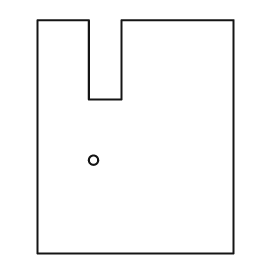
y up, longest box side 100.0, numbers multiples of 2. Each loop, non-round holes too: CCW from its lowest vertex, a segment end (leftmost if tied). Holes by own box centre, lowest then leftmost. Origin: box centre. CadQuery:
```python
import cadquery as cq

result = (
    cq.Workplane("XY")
    .moveTo(-42.0, -50.0)
    .lineTo(42.0, -50.0)
    .lineTo(42.0, 50.0)
    .lineTo(-6.0, 50.0)
    .lineTo(-6.0, 16.0)
    .lineTo(-20.0, 16.0)
    .lineTo(-20.0, 50.0)
    .lineTo(-42.0, 50.0)
    .close()
    .moveTo(-18.0, -10.0)
    .circle(2.0)
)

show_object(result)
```